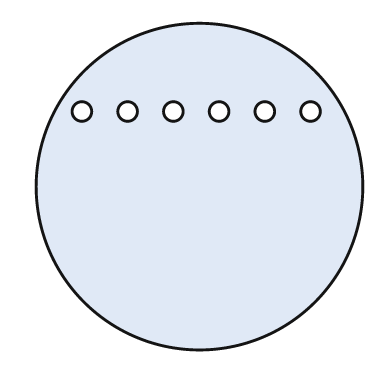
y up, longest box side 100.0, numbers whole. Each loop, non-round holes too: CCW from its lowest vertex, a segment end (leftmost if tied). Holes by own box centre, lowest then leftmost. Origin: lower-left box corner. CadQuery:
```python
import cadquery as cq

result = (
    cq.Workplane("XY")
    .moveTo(50.0, 50.0)
    .circle(50.0)
    .moveTo(14.0, 73.0)
    .circle(3.0)
    .moveTo(28.0, 73.0)
    .circle(3.0)
    .moveTo(42.0, 73.0)
    .circle(3.0)
    .moveTo(56.0, 73.0)
    .circle(3.0)
    .moveTo(70.0, 73.0)
    .circle(3.0)
    .moveTo(84.0, 73.0)
    .circle(3.0)
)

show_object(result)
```